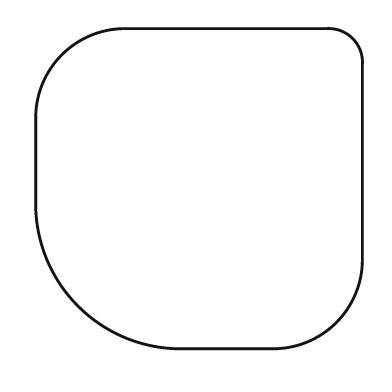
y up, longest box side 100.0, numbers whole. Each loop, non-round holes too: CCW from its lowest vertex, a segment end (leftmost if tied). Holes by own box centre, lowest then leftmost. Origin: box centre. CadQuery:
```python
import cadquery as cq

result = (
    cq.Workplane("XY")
    .moveTo(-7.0, -49.0)
    .lineTo(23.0, -49.0)
    .threePointArc((42.0, -41.0), (50.0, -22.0))
    .lineTo(50.0, 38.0)
    .threePointArc((47.0, 46.0), (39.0, 49.0))
    .lineTo(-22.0, 49.0)
    .threePointArc((-42.0, 41.0), (-50.0, 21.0))
    .lineTo(-50.0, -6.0)
    .threePointArc((-37.0, -36.0), (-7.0, -49.0))
    .close()
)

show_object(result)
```